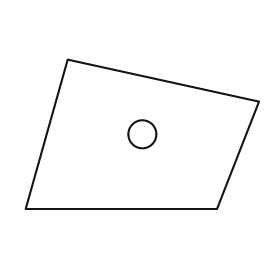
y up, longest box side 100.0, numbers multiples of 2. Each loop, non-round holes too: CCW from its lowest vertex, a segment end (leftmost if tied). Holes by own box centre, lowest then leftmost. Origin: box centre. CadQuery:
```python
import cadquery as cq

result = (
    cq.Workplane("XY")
    .moveTo(-50.0, -32.0)
    .lineTo(32.0, -32.0)
    .lineTo(50.0, 14.0)
    .lineTo(-32.0, 32.0)
    .close()
    .moveTo(0.0, 0.0)
    .circle(6.0)
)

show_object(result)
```